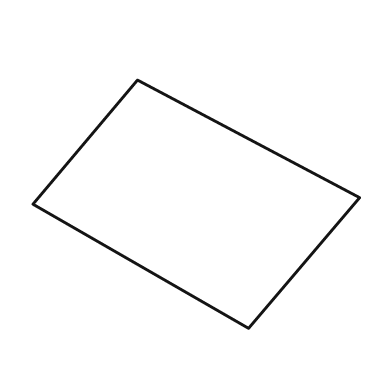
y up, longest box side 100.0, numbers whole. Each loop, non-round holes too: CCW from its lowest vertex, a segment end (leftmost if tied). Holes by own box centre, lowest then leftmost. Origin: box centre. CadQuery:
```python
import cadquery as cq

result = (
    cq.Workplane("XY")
    .moveTo(16.0, -38.0)
    .lineTo(50.0, 2.0)
    .lineTo(-18.0, 38.0)
    .lineTo(-50.0, 0.0)
    .close()
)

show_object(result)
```